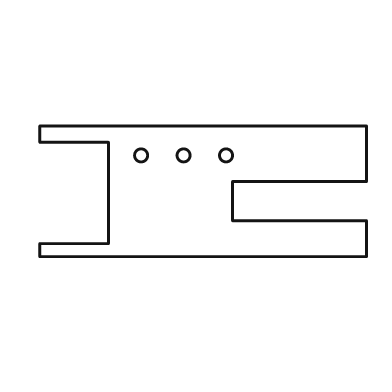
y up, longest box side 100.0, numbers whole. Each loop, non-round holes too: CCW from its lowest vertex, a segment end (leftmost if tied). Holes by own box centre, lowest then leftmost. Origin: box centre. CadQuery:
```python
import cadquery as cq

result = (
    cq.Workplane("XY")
    .moveTo(-50.0, -20.0)
    .lineTo(50.0, -20.0)
    .lineTo(50.0, -9.0)
    .lineTo(9.0, -9.0)
    .lineTo(9.0, 3.0)
    .lineTo(50.0, 3.0)
    .lineTo(50.0, 20.0)
    .lineTo(-50.0, 20.0)
    .lineTo(-50.0, 15.0)
    .lineTo(-29.0, 15.0)
    .lineTo(-29.0, -16.0)
    .lineTo(-50.0, -16.0)
    .close()
    .moveTo(-19.0, 11.0)
    .circle(2.0)
    .moveTo(-6.0, 11.0)
    .circle(2.0)
    .moveTo(7.0, 11.0)
    .circle(2.0)
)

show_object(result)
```